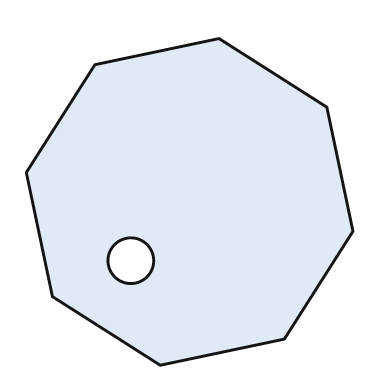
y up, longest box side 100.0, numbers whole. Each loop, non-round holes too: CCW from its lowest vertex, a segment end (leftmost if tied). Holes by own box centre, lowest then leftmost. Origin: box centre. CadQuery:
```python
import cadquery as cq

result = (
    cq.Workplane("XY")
    .moveTo(-9.0, -50.0)
    .lineTo(29.0, -42.0)
    .lineTo(50.0, -9.0)
    .lineTo(42.0, 29.0)
    .lineTo(9.0, 50.0)
    .lineTo(-29.0, 42.0)
    .lineTo(-50.0, 9.0)
    .lineTo(-42.0, -29.0)
    .close()
    .moveTo(-18.0, -18.0)
    .circle(7.0)
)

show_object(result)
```